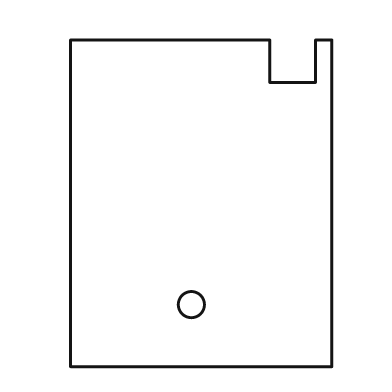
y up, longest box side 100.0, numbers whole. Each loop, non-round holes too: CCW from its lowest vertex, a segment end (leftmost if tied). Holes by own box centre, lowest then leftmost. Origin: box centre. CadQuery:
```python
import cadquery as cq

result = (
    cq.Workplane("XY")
    .moveTo(-40.0, -50.0)
    .lineTo(40.0, -50.0)
    .lineTo(40.0, 50.0)
    .lineTo(35.0, 50.0)
    .lineTo(35.0, 37.0)
    .lineTo(21.0, 37.0)
    .lineTo(21.0, 50.0)
    .lineTo(-40.0, 50.0)
    .close()
    .moveTo(-3.0, -31.0)
    .circle(4.0)
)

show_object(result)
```